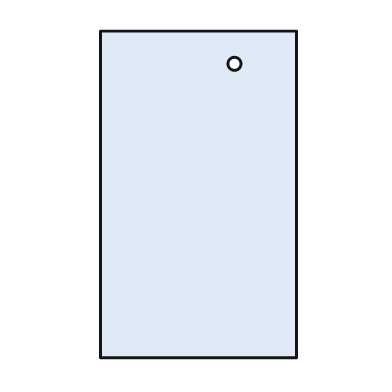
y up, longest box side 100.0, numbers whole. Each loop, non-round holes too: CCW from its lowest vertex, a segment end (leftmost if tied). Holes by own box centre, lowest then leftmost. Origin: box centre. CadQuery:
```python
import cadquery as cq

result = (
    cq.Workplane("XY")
    .moveTo(-30.0, -50.0)
    .lineTo(30.0, -50.0)
    .lineTo(30.0, 50.0)
    .lineTo(-30.0, 50.0)
    .close()
    .moveTo(11.0, 40.0)
    .circle(2.0)
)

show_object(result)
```